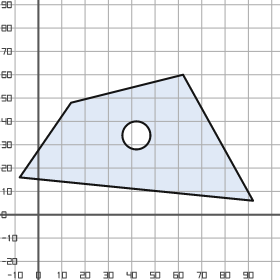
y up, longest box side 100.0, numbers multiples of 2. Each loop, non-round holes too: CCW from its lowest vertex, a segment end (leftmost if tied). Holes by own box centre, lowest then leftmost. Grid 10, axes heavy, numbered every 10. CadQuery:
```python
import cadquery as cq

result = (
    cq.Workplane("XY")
    .moveTo(92.0, 6.0)
    .lineTo(62.0, 60.0)
    .lineTo(14.0, 48.0)
    .lineTo(-8.0, 16.0)
    .close()
    .moveTo(42.0, 34.0)
    .circle(6.0)
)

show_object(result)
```